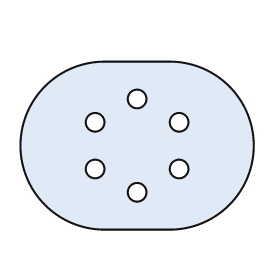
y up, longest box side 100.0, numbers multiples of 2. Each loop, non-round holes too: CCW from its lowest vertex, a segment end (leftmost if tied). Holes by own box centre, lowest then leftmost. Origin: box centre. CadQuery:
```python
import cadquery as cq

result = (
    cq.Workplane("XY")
    .moveTo(-14.0, -36.0)
    .lineTo(14.0, -36.0)
    .threePointArc((50.0, 0.0), (14.0, 36.0))
    .lineTo(-14.0, 36.0)
    .threePointArc((-50.0, 0.0), (-14.0, -36.0))
    .close()
    .moveTo(0.0, -20.0)
    .circle(4.0)
    .moveTo(-18.0, -10.0)
    .circle(4.0)
    .moveTo(18.0, -10.0)
    .circle(4.0)
    .moveTo(-18.0, 10.0)
    .circle(4.0)
    .moveTo(18.0, 10.0)
    .circle(4.0)
    .moveTo(0.0, 20.0)
    .circle(4.0)
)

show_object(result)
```